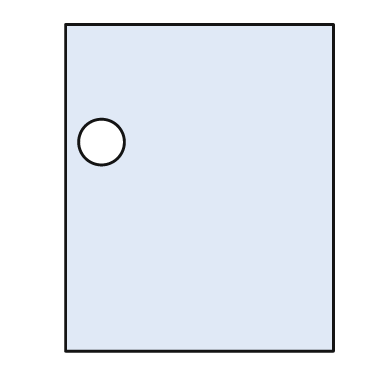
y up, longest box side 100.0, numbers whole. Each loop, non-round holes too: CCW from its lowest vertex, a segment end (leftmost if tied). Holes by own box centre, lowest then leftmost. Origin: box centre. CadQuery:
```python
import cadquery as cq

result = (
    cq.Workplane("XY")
    .moveTo(-41.0, -50.0)
    .lineTo(41.0, -50.0)
    .lineTo(41.0, 50.0)
    .lineTo(-41.0, 50.0)
    .close()
    .moveTo(-30.0, 14.0)
    .circle(7.0)
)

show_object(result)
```